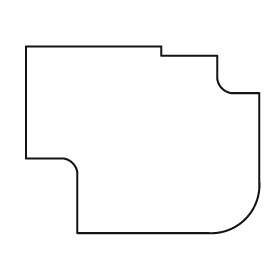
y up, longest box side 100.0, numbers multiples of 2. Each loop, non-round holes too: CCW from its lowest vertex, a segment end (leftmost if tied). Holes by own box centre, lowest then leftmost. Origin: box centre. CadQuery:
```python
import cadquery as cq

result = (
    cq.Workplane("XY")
    .moveTo(-28.0, -40.0)
    .lineTo(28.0, -40.0)
    .threePointArc((44.0, -34.0), (50.0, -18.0))
    .lineTo(50.0, 20.0)
    .lineTo(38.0, 20.0)
    .threePointArc((34.0, 22.0), (32.0, 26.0))
    .lineTo(32.0, 36.0)
    .lineTo(8.0, 36.0)
    .lineTo(8.0, 40.0)
    .lineTo(-50.0, 40.0)
    .lineTo(-50.0, -8.0)
    .lineTo(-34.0, -8.0)
    .threePointArc((-30.0, -10.0), (-28.0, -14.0))
    .close()
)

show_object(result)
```